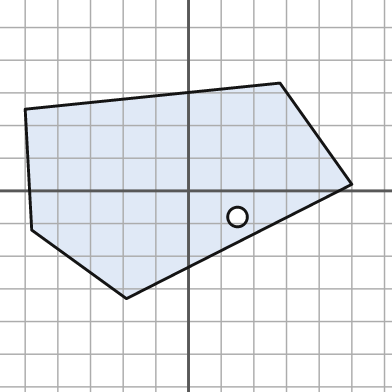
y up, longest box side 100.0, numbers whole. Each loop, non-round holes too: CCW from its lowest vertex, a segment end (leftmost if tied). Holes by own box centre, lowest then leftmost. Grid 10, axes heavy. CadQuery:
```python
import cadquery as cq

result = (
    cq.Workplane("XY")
    .moveTo(-19.0, -33.0)
    .lineTo(50.0, 2.0)
    .lineTo(28.0, 33.0)
    .lineTo(-50.0, 25.0)
    .lineTo(-48.0, -12.0)
    .close()
    .moveTo(15.0, -8.0)
    .circle(3.0)
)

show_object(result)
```